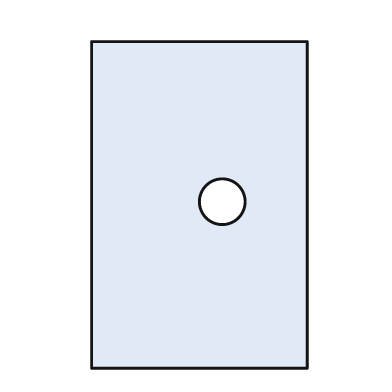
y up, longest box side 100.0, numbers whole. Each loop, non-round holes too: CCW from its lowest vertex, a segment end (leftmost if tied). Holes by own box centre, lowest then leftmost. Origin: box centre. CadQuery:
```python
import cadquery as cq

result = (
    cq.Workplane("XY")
    .moveTo(-33.0, -50.0)
    .lineTo(33.0, -50.0)
    .lineTo(33.0, 50.0)
    .lineTo(-33.0, 50.0)
    .close()
    .moveTo(7.0, 1.0)
    .circle(7.0)
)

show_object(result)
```